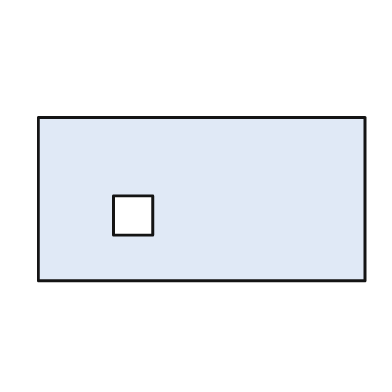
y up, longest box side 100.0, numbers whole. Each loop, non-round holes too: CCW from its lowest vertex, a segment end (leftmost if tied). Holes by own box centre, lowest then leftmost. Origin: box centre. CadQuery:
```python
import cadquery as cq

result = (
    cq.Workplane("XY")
    .moveTo(-50.0, -25.0)
    .lineTo(50.0, -25.0)
    .lineTo(50.0, 25.0)
    .lineTo(-50.0, 25.0)
    .close()
    .moveTo(-27.0, -11.0)
    .lineTo(-15.0, -11.0)
    .lineTo(-15.0, 1.0)
    .lineTo(-27.0, 1.0)
    .close()
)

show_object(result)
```